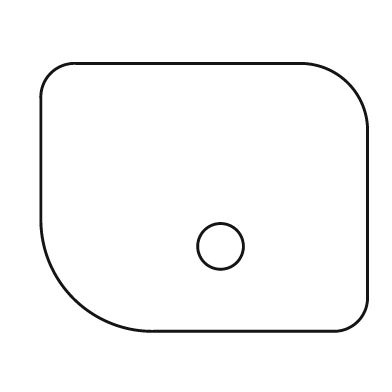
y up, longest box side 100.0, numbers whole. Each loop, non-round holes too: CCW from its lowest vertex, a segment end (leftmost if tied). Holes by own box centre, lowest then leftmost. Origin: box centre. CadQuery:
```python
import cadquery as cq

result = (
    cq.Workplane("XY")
    .moveTo(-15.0, -41.0)
    .lineTo(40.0, -41.0)
    .threePointArc((47.0, -38.0), (50.0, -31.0))
    .lineTo(50.0, 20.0)
    .threePointArc((44.0, 35.0), (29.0, 41.0))
    .lineTo(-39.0, 41.0)
    .threePointArc((-47.0, 38.0), (-50.0, 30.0))
    .lineTo(-50.0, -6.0)
    .threePointArc((-40.0, -31.0), (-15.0, -41.0))
    .close()
    .moveTo(5.0, -15.0)
    .circle(7.0)
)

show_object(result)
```